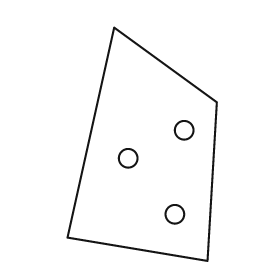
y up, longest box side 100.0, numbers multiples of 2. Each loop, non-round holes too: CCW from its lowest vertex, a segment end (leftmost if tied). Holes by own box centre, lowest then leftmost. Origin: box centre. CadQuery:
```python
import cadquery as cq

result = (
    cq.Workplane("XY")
    .moveTo(28.0, -50.0)
    .lineTo(32.0, 18.0)
    .lineTo(-12.0, 50.0)
    .lineTo(-32.0, -40.0)
    .close()
    .moveTo(14.0, -30.0)
    .circle(4.0)
    .moveTo(-6.0, -6.0)
    .circle(4.0)
    .moveTo(18.0, 6.0)
    .circle(4.0)
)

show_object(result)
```